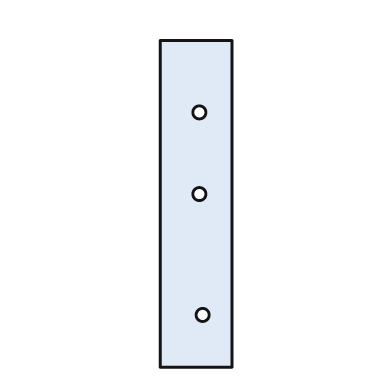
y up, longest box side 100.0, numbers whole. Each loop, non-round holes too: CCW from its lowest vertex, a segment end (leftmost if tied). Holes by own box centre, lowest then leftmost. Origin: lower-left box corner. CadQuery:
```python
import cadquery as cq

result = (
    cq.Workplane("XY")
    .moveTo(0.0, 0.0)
    .lineTo(22.0, 0.0)
    .lineTo(22.0, 100.0)
    .lineTo(0.0, 100.0)
    .close()
    .moveTo(13.0, 16.0)
    .circle(2.0)
    .moveTo(12.0, 53.0)
    .circle(2.0)
    .moveTo(12.0, 78.0)
    .circle(2.0)
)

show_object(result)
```